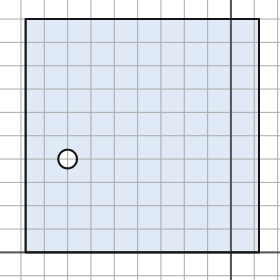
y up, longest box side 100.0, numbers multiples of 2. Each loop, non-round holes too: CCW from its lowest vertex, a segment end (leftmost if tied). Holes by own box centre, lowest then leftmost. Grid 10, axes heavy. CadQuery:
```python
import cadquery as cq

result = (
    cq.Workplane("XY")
    .moveTo(-88.0, 0.0)
    .lineTo(12.0, 0.0)
    .lineTo(12.0, 100.0)
    .lineTo(-88.0, 100.0)
    .close()
    .moveTo(-70.0, 40.0)
    .circle(4.0)
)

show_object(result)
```